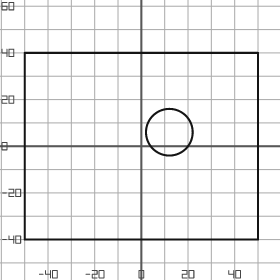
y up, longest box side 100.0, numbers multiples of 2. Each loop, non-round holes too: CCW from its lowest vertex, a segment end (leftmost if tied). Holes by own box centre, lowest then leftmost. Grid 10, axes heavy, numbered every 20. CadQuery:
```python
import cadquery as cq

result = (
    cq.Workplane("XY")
    .moveTo(-50.0, -40.0)
    .lineTo(50.0, -40.0)
    .lineTo(50.0, 40.0)
    .lineTo(-50.0, 40.0)
    .close()
    .moveTo(12.0, 6.0)
    .circle(10.0)
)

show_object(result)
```